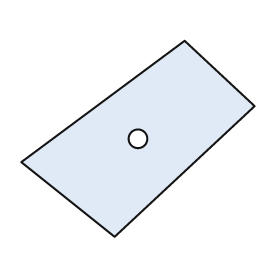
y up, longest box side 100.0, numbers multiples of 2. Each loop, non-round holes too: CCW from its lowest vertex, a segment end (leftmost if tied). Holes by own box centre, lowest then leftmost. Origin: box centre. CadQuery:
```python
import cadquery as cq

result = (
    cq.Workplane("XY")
    .moveTo(-10.0, -42.0)
    .lineTo(50.0, 14.0)
    .lineTo(20.0, 42.0)
    .lineTo(-50.0, -10.0)
    .close()
    .moveTo(0.0, 0.0)
    .circle(4.0)
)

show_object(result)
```